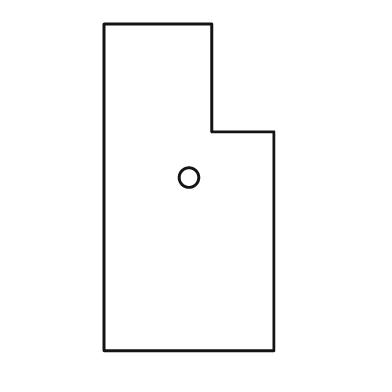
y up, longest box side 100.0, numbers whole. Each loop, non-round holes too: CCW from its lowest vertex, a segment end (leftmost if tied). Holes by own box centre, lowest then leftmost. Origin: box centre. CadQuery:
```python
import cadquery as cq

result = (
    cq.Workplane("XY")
    .moveTo(-26.0, -50.0)
    .lineTo(26.0, -50.0)
    .lineTo(26.0, 17.0)
    .lineTo(7.0, 17.0)
    .lineTo(7.0, 50.0)
    .lineTo(-26.0, 50.0)
    .close()
    .moveTo(0.0, 3.0)
    .circle(3.0)
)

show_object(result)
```